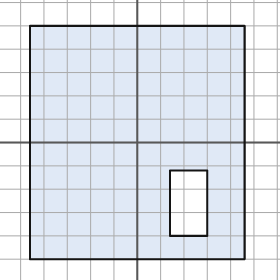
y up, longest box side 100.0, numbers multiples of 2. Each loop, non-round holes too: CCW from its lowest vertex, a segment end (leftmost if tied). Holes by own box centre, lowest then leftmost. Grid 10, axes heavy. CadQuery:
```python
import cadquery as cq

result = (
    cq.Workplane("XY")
    .moveTo(-46.0, -50.0)
    .lineTo(46.0, -50.0)
    .lineTo(46.0, 50.0)
    .lineTo(-46.0, 50.0)
    .close()
    .moveTo(14.0, -40.0)
    .lineTo(30.0, -40.0)
    .lineTo(30.0, -12.0)
    .lineTo(14.0, -12.0)
    .close()
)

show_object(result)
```